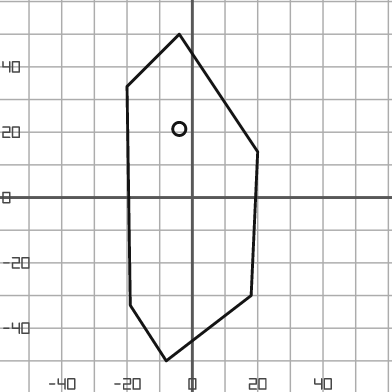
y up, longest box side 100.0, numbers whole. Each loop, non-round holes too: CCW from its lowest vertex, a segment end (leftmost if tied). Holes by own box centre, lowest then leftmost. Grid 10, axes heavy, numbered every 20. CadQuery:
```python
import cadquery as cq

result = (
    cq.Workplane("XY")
    .moveTo(-8.0, -50.0)
    .lineTo(18.0, -30.0)
    .lineTo(20.0, 14.0)
    .lineTo(-4.0, 50.0)
    .lineTo(-20.0, 34.0)
    .lineTo(-19.0, -33.0)
    .close()
    .moveTo(-4.0, 21.0)
    .circle(2.0)
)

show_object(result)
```